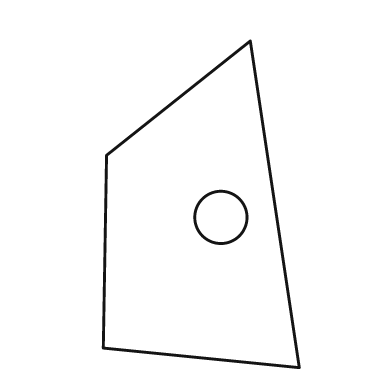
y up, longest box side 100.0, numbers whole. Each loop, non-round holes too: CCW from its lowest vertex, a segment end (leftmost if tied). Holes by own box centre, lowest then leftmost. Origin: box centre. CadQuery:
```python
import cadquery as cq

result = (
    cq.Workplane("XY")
    .moveTo(30.0, -50.0)
    .lineTo(15.0, 50.0)
    .lineTo(-29.0, 15.0)
    .lineTo(-30.0, -44.0)
    .close()
    .moveTo(6.0, -4.0)
    .circle(8.0)
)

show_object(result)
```